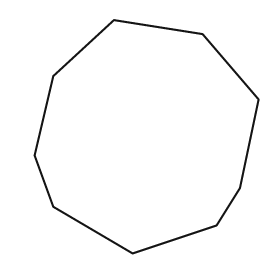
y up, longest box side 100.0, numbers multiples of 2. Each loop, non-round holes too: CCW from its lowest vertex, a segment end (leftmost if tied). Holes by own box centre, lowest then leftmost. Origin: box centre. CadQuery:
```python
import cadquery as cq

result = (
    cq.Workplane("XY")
    .moveTo(-6.0, -50.0)
    .lineTo(30.0, -38.0)
    .lineTo(40.0, -22.0)
    .lineTo(48.0, 16.0)
    .lineTo(24.0, 44.0)
    .lineTo(-14.0, 50.0)
    .lineTo(-40.0, 26.0)
    .lineTo(-48.0, -8.0)
    .lineTo(-40.0, -30.0)
    .close()
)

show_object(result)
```